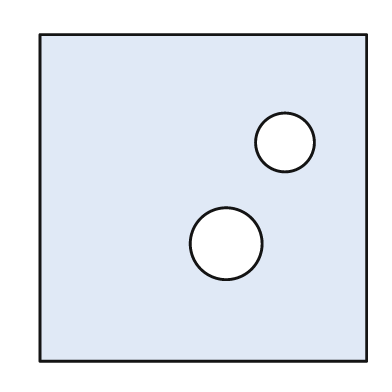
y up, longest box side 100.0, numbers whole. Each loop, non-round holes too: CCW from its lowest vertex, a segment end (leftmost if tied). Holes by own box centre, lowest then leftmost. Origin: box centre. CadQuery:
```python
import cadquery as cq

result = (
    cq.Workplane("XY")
    .moveTo(-50.0, -50.0)
    .lineTo(50.0, -50.0)
    .lineTo(50.0, 50.0)
    .lineTo(-50.0, 50.0)
    .close()
    .moveTo(7.0, -14.0)
    .circle(11.0)
    .moveTo(25.0, 17.0)
    .circle(9.0)
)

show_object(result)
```